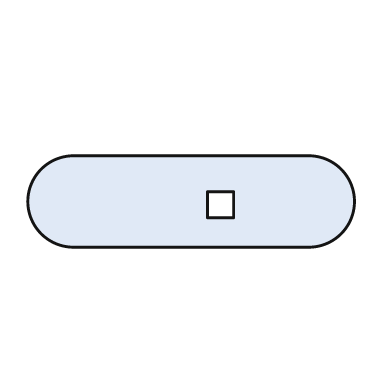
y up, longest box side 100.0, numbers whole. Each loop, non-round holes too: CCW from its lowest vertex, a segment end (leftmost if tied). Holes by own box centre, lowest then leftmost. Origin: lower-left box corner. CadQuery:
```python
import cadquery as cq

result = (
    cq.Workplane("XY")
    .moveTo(14.0, 0.0)
    .lineTo(86.0, 0.0)
    .threePointArc((100.0, 14.0), (86.0, 28.0))
    .lineTo(14.0, 28.0)
    .threePointArc((0.0, 14.0), (14.0, 0.0))
    .close()
    .moveTo(55.0, 9.0)
    .lineTo(63.0, 9.0)
    .lineTo(63.0, 17.0)
    .lineTo(55.0, 17.0)
    .close()
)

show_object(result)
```